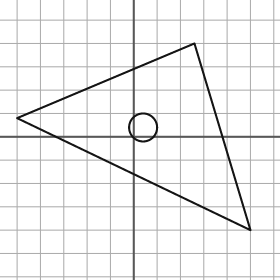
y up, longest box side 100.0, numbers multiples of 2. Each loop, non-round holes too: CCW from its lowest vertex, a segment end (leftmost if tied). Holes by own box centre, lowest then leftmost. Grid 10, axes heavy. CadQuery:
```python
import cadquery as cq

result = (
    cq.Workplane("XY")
    .moveTo(50.0, -40.0)
    .lineTo(26.0, 40.0)
    .lineTo(-50.0, 8.0)
    .close()
    .moveTo(4.0, 4.0)
    .circle(6.0)
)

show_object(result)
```